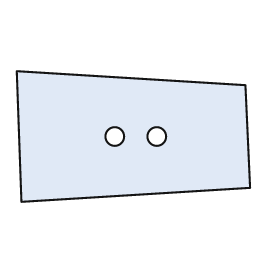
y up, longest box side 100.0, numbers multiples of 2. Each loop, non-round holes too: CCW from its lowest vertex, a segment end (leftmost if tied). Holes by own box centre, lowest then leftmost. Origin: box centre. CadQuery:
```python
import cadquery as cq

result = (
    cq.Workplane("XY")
    .moveTo(-48.0, -28.0)
    .lineTo(50.0, -22.0)
    .lineTo(48.0, 22.0)
    .lineTo(-50.0, 28.0)
    .close()
    .moveTo(-8.0, 0.0)
    .circle(4.0)
    .moveTo(10.0, 0.0)
    .circle(4.0)
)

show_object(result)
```